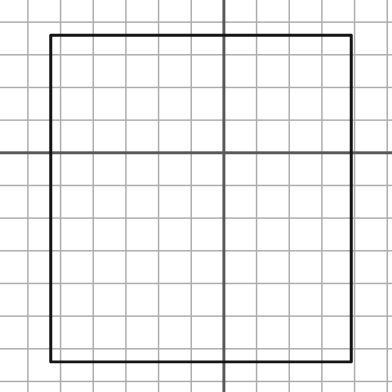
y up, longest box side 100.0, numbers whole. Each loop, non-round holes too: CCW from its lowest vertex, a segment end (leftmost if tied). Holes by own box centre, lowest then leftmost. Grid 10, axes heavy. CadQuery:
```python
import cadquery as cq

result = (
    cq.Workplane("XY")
    .moveTo(-53.0, -64.0)
    .lineTo(39.0, -64.0)
    .lineTo(39.0, 36.0)
    .lineTo(-53.0, 36.0)
    .close()
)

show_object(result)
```